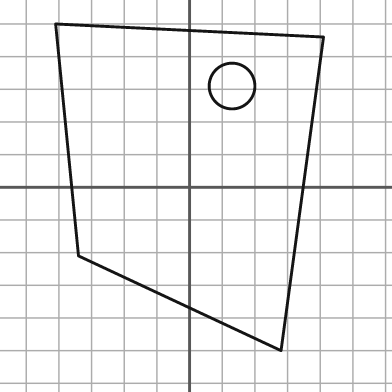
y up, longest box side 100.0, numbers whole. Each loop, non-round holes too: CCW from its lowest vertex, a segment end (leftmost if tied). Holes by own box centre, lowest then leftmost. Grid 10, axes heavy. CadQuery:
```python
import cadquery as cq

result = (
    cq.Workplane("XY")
    .moveTo(28.0, -50.0)
    .lineTo(41.0, 46.0)
    .lineTo(-41.0, 50.0)
    .lineTo(-34.0, -21.0)
    .close()
    .moveTo(13.0, 31.0)
    .circle(7.0)
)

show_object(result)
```